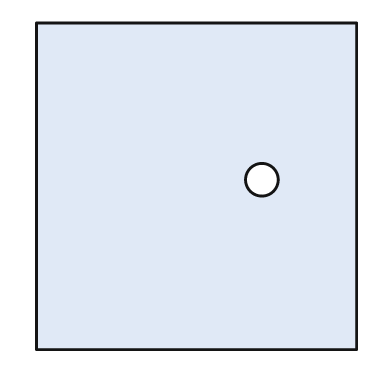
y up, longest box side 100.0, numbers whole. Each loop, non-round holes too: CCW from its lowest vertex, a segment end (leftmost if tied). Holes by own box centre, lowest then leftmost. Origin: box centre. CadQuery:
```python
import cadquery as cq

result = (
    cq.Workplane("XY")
    .moveTo(-49.0, -50.0)
    .lineTo(49.0, -50.0)
    .lineTo(49.0, 50.0)
    .lineTo(-49.0, 50.0)
    .close()
    .moveTo(20.0, 2.0)
    .circle(5.0)
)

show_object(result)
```